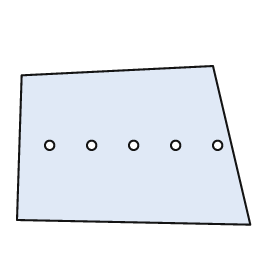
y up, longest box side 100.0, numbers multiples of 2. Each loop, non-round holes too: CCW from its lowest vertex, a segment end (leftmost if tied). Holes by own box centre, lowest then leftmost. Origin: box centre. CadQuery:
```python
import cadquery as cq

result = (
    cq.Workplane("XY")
    .moveTo(50.0, -34.0)
    .lineTo(34.0, 34.0)
    .lineTo(-48.0, 30.0)
    .lineTo(-50.0, -32.0)
    .close()
    .moveTo(-36.0, 0.0)
    .circle(2.0)
    .moveTo(-18.0, 0.0)
    .circle(2.0)
    .moveTo(0.0, 0.0)
    .circle(2.0)
    .moveTo(18.0, 0.0)
    .circle(2.0)
    .moveTo(36.0, 0.0)
    .circle(2.0)
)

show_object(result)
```